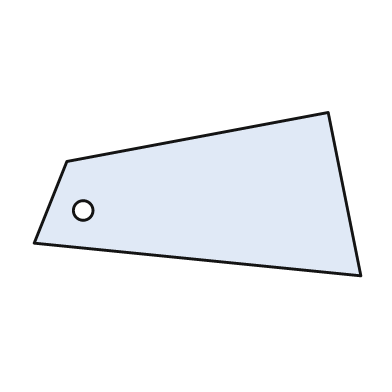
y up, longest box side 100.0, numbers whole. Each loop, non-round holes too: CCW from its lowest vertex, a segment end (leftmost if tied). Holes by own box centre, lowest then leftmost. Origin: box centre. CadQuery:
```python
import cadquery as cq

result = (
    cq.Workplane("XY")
    .moveTo(50.0, -25.0)
    .lineTo(40.0, 25.0)
    .lineTo(-40.0, 10.0)
    .lineTo(-50.0, -15.0)
    .close()
    .moveTo(-35.0, -5.0)
    .circle(3.0)
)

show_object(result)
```